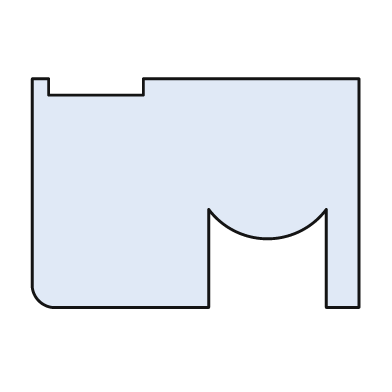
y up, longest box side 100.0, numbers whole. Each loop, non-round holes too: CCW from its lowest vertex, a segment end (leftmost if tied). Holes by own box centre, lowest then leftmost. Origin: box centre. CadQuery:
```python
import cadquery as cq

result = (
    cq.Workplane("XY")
    .moveTo(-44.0, -35.0)
    .lineTo(4.0, -35.0)
    .lineTo(4.0, -5.0)
    .threePointArc((22.0, -14.0), (40.0, -5.0))
    .lineTo(40.0, -35.0)
    .lineTo(50.0, -35.0)
    .lineTo(50.0, 35.0)
    .lineTo(-16.0, 35.0)
    .lineTo(-16.0, 30.0)
    .lineTo(-45.0, 30.0)
    .lineTo(-45.0, 35.0)
    .lineTo(-50.0, 35.0)
    .lineTo(-50.0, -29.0)
    .threePointArc((-48.0, -33.0), (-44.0, -35.0))
    .close()
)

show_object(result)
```